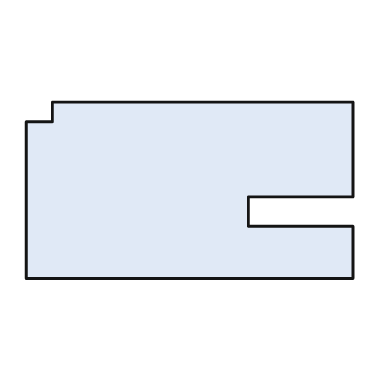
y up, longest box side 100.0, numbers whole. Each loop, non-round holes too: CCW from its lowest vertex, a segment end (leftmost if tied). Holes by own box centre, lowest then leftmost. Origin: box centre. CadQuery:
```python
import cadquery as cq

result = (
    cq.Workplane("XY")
    .moveTo(-50.0, -27.0)
    .lineTo(50.0, -27.0)
    .lineTo(50.0, -11.0)
    .lineTo(18.0, -11.0)
    .lineTo(18.0, -2.0)
    .lineTo(50.0, -2.0)
    .lineTo(50.0, 27.0)
    .lineTo(-42.0, 27.0)
    .lineTo(-42.0, 21.0)
    .lineTo(-50.0, 21.0)
    .close()
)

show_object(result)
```